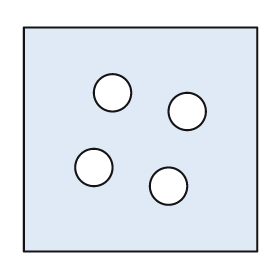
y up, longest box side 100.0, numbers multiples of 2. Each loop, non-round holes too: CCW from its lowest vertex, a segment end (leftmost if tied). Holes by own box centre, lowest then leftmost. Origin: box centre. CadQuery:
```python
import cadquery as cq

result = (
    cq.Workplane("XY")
    .moveTo(-50.0, -48.0)
    .lineTo(50.0, -48.0)
    .lineTo(50.0, 48.0)
    .lineTo(-50.0, 48.0)
    .close()
    .moveTo(12.0, -20.0)
    .circle(8.0)
    .moveTo(-20.0, -12.0)
    .circle(8.0)
    .moveTo(20.0, 12.0)
    .circle(8.0)
    .moveTo(-12.0, 20.0)
    .circle(8.0)
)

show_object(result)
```